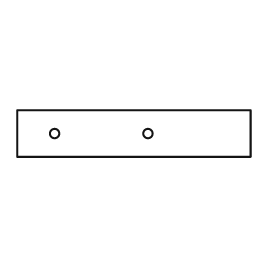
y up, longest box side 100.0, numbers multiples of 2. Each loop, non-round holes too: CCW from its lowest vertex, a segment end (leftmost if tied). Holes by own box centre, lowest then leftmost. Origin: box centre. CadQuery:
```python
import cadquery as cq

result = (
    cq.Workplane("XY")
    .moveTo(-50.0, -10.0)
    .lineTo(50.0, -10.0)
    .lineTo(50.0, 10.0)
    .lineTo(-50.0, 10.0)
    .close()
    .moveTo(-34.0, 0.0)
    .circle(2.0)
    .moveTo(6.0, 0.0)
    .circle(2.0)
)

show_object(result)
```